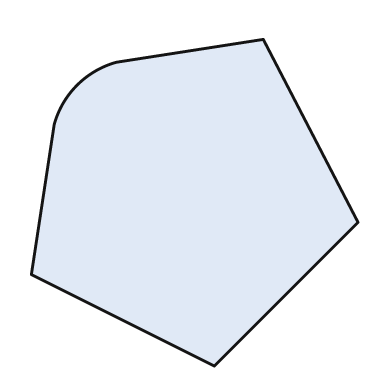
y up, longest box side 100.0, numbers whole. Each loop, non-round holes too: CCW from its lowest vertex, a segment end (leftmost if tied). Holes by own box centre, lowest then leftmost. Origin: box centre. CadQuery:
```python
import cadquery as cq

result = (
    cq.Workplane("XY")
    .moveTo(6.0, -50.0)
    .lineTo(50.0, -6.0)
    .lineTo(21.0, 50.0)
    .lineTo(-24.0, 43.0)
    .threePointArc((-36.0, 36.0), (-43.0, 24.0))
    .lineTo(-50.0, -22.0)
    .close()
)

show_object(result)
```